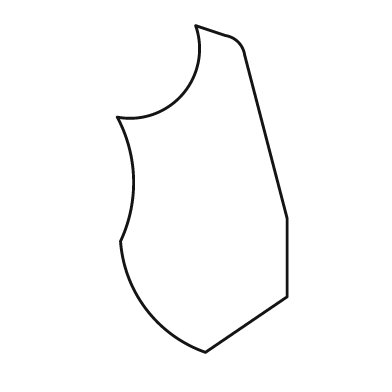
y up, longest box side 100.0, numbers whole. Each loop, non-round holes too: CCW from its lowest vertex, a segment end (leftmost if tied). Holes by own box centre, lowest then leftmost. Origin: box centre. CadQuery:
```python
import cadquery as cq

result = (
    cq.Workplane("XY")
    .moveTo(1.0, -50.0)
    .lineTo(26.0, -33.0)
    .lineTo(26.0, -9.0)
    .lineTo(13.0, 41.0)
    .threePointArc((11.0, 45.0), (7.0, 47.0))
    .lineTo(-2.0, 50.0)
    .threePointArc((-6.0, 29.0), (-26.0, 22.0))
    .threePointArc((-21.0, 3.0), (-25.0, -16.0))
    .threePointArc((-17.0, -37.0), (1.0, -50.0))
    .close()
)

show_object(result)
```